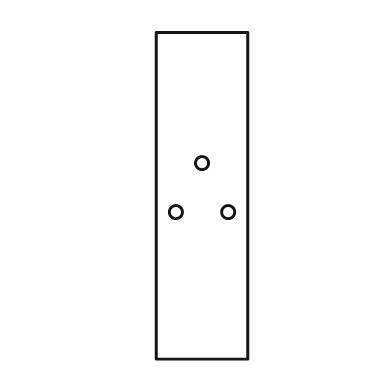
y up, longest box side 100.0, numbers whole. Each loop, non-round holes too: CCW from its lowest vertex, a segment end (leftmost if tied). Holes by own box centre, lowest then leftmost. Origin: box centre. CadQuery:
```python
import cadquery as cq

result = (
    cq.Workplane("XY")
    .moveTo(-14.0, -50.0)
    .lineTo(14.0, -50.0)
    .lineTo(14.0, 50.0)
    .lineTo(-14.0, 50.0)
    .close()
    .moveTo(-8.0, -5.0)
    .circle(2.0)
    .moveTo(8.0, -5.0)
    .circle(2.0)
    .moveTo(0.0, 10.0)
    .circle(2.0)
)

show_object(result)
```